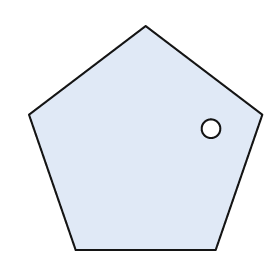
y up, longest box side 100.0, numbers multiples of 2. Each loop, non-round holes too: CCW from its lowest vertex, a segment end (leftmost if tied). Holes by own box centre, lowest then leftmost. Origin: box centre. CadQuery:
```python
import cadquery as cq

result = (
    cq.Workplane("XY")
    .moveTo(-30.0, -48.0)
    .lineTo(30.0, -48.0)
    .lineTo(50.0, 10.0)
    .lineTo(0.0, 48.0)
    .lineTo(-50.0, 10.0)
    .close()
    .moveTo(28.0, 4.0)
    .circle(4.0)
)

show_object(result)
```